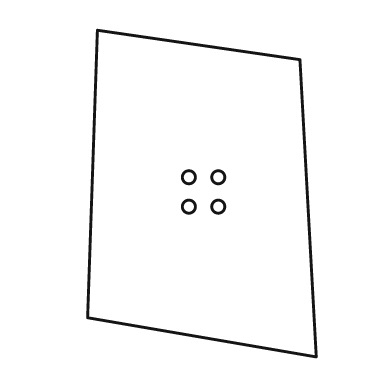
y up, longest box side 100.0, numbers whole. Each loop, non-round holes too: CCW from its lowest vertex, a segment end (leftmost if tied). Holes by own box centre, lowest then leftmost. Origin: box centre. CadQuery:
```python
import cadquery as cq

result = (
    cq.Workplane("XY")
    .moveTo(35.0, -50.0)
    .lineTo(30.0, 41.0)
    .lineTo(-32.0, 50.0)
    .lineTo(-35.0, -38.0)
    .close()
    .moveTo(-4.0, -4.0)
    .circle(2.0)
    .moveTo(5.0, -4.0)
    .circle(2.0)
    .moveTo(-4.0, 5.0)
    .circle(2.0)
    .moveTo(5.0, 5.0)
    .circle(2.0)
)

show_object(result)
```